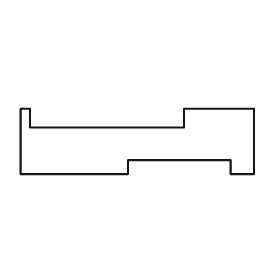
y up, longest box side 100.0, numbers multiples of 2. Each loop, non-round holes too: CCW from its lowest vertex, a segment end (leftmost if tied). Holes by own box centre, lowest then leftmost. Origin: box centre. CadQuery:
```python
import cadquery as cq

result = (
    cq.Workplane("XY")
    .moveTo(-50.0, -14.0)
    .lineTo(-4.0, -14.0)
    .lineTo(-4.0, -8.0)
    .lineTo(40.0, -8.0)
    .lineTo(40.0, -14.0)
    .lineTo(50.0, -14.0)
    .lineTo(50.0, 14.0)
    .lineTo(20.0, 14.0)
    .lineTo(20.0, 6.0)
    .lineTo(-46.0, 6.0)
    .lineTo(-46.0, 14.0)
    .lineTo(-50.0, 14.0)
    .close()
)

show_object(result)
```